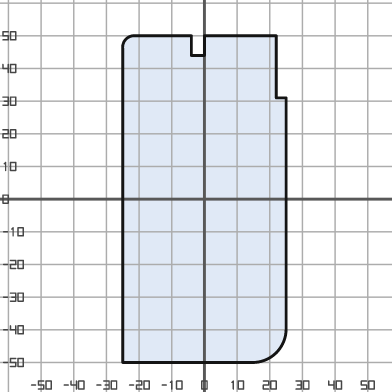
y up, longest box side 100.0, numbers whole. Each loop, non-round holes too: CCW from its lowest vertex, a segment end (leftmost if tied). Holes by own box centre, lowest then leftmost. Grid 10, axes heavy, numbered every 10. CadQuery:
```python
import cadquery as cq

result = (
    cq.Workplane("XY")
    .moveTo(-25.0, -50.0)
    .lineTo(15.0, -50.0)
    .threePointArc((22.0, -47.0), (25.0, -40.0))
    .lineTo(25.0, 31.0)
    .lineTo(22.0, 31.0)
    .lineTo(22.0, 50.0)
    .lineTo(0.0, 50.0)
    .lineTo(0.0, 44.0)
    .lineTo(-4.0, 44.0)
    .lineTo(-4.0, 50.0)
    .lineTo(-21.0, 50.0)
    .threePointArc((-24.0, 49.0), (-25.0, 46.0))
    .close()
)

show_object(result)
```